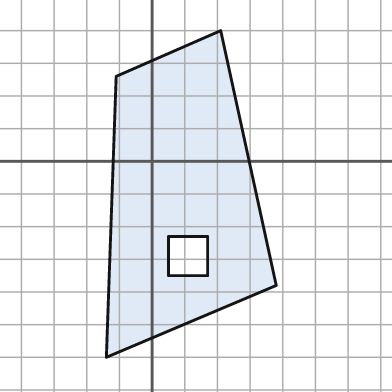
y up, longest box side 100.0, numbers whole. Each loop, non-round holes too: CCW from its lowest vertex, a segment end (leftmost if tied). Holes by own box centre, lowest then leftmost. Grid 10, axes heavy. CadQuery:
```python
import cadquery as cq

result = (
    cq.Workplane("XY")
    .moveTo(-14.0, -60.0)
    .lineTo(38.0, -38.0)
    .lineTo(21.0, 40.0)
    .lineTo(-11.0, 26.0)
    .close()
    .moveTo(5.0, -35.0)
    .lineTo(17.0, -35.0)
    .lineTo(17.0, -23.0)
    .lineTo(5.0, -23.0)
    .close()
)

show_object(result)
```